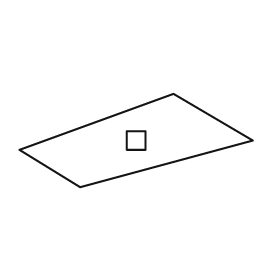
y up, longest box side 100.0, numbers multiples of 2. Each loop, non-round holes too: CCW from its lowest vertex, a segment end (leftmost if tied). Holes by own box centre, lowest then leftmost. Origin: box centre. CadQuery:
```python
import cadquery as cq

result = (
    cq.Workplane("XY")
    .moveTo(-24.0, -20.0)
    .lineTo(50.0, 0.0)
    .lineTo(16.0, 20.0)
    .lineTo(-50.0, -4.0)
    .close()
    .moveTo(-4.0, -4.0)
    .lineTo(4.0, -4.0)
    .lineTo(4.0, 4.0)
    .lineTo(-4.0, 4.0)
    .close()
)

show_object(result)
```